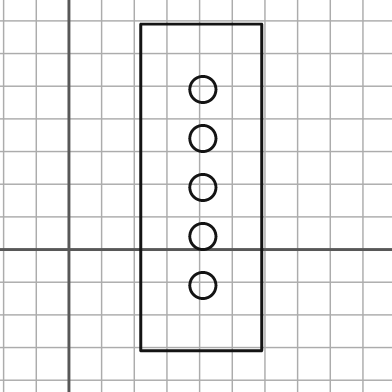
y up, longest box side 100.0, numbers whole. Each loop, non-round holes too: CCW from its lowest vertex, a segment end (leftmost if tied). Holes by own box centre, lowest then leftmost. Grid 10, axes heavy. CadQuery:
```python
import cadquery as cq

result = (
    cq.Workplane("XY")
    .moveTo(22.0, -31.0)
    .lineTo(59.0, -31.0)
    .lineTo(59.0, 69.0)
    .lineTo(22.0, 69.0)
    .close()
    .moveTo(41.0, -11.0)
    .circle(4.0)
    .moveTo(41.0, 4.0)
    .circle(4.0)
    .moveTo(41.0, 19.0)
    .circle(4.0)
    .moveTo(41.0, 34.0)
    .circle(4.0)
    .moveTo(41.0, 49.0)
    .circle(4.0)
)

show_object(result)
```